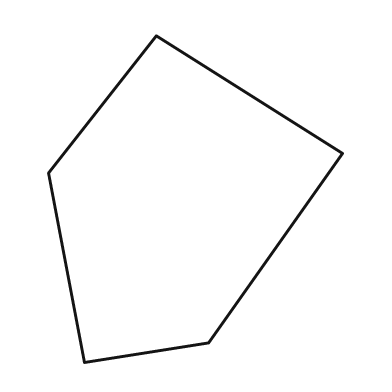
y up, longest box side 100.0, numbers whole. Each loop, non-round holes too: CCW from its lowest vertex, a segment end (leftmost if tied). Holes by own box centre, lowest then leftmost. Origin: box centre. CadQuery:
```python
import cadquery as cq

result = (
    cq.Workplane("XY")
    .moveTo(-34.0, -50.0)
    .lineTo(4.0, -44.0)
    .lineTo(45.0, 14.0)
    .lineTo(-12.0, 50.0)
    .lineTo(-45.0, 8.0)
    .close()
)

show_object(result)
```